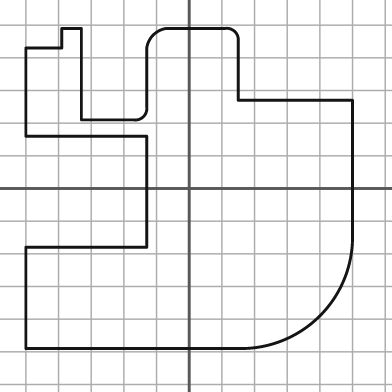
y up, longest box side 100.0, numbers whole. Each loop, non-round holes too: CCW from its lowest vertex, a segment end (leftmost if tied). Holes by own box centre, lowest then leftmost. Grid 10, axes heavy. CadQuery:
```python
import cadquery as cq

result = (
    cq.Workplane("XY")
    .moveTo(-50.0, -49.0)
    .lineTo(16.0, -49.0)
    .threePointArc((40.0, -39.0), (50.0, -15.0))
    .lineTo(50.0, 27.0)
    .lineTo(15.0, 27.0)
    .lineTo(15.0, 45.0)
    .threePointArc((14.0, 48.0), (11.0, 49.0))
    .lineTo(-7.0, 49.0)
    .threePointArc((-11.0, 47.0), (-13.0, 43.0))
    .lineTo(-13.0, 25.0)
    .threePointArc((-14.0, 22.0), (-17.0, 21.0))
    .lineTo(-33.0, 21.0)
    .lineTo(-33.0, 49.0)
    .lineTo(-39.0, 49.0)
    .lineTo(-39.0, 43.0)
    .lineTo(-50.0, 43.0)
    .lineTo(-50.0, 16.0)
    .lineTo(-13.0, 16.0)
    .lineTo(-13.0, -18.0)
    .lineTo(-50.0, -18.0)
    .close()
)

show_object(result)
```